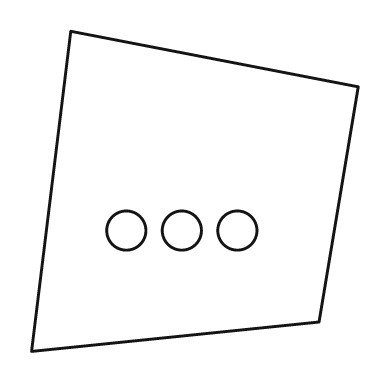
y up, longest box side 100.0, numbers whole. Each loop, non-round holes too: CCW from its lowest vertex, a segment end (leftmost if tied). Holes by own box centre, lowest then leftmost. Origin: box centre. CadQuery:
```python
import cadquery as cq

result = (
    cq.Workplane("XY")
    .moveTo(-50.0, -49.0)
    .lineTo(38.0, -40.0)
    .lineTo(50.0, 32.0)
    .lineTo(-38.0, 49.0)
    .close()
    .moveTo(-21.0, -12.0)
    .circle(6.0)
    .moveTo(-4.0, -12.0)
    .circle(6.0)
    .moveTo(13.0, -12.0)
    .circle(6.0)
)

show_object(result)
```